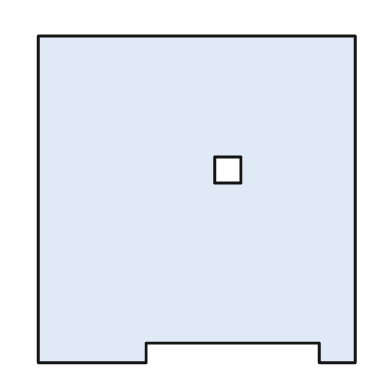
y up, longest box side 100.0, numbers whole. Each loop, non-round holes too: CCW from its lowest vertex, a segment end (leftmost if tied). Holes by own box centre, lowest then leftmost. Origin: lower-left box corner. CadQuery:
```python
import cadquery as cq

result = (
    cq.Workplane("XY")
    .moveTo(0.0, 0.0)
    .lineTo(33.0, 0.0)
    .lineTo(33.0, 6.0)
    .lineTo(86.0, 6.0)
    .lineTo(86.0, 0.0)
    .lineTo(97.0, 0.0)
    .lineTo(97.0, 100.0)
    .lineTo(0.0, 100.0)
    .close()
    .moveTo(54.0, 55.0)
    .lineTo(62.0, 55.0)
    .lineTo(62.0, 63.0)
    .lineTo(54.0, 63.0)
    .close()
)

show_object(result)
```